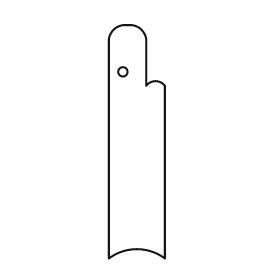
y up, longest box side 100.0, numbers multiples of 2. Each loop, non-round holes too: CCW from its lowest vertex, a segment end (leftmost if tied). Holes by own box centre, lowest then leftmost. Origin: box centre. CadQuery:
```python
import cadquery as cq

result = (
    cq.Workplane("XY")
    .moveTo(-12.0, -50.0)
    .threePointArc((0.0, -46.0), (12.0, -50.0))
    .lineTo(12.0, 24.0)
    .threePointArc((8.0, 26.0), (4.0, 24.0))
    .lineTo(4.0, 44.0)
    .threePointArc((2.0, 48.0), (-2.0, 50.0))
    .lineTo(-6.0, 50.0)
    .threePointArc((-10.0, 48.0), (-12.0, 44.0))
    .close()
    .moveTo(-6.0, 30.0)
    .circle(2.0)
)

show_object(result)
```